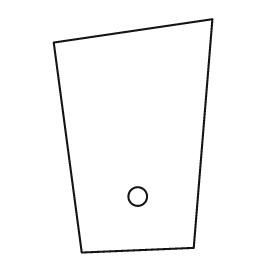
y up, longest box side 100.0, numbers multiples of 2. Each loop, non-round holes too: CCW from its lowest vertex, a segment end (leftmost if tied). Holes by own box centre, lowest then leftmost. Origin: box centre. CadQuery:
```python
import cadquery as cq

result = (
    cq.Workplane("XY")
    .moveTo(-22.0, -50.0)
    .lineTo(26.0, -48.0)
    .lineTo(34.0, 50.0)
    .lineTo(-34.0, 40.0)
    .close()
    .moveTo(2.0, -26.0)
    .circle(4.0)
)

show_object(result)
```